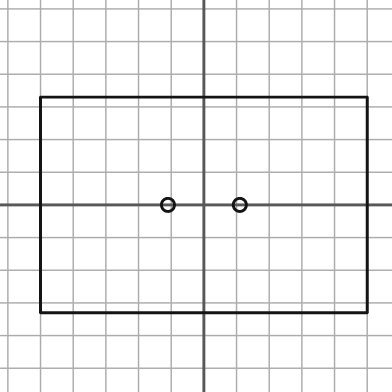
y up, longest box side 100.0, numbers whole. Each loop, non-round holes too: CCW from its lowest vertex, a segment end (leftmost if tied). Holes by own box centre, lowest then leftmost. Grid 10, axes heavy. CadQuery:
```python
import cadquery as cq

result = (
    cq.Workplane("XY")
    .moveTo(-50.0, -33.0)
    .lineTo(50.0, -33.0)
    .lineTo(50.0, 33.0)
    .lineTo(-50.0, 33.0)
    .close()
    .moveTo(-11.0, 0.0)
    .circle(2.0)
    .moveTo(11.0, 0.0)
    .circle(2.0)
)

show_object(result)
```